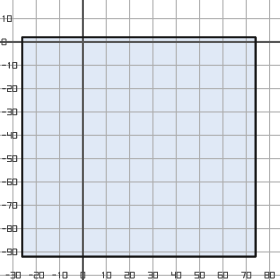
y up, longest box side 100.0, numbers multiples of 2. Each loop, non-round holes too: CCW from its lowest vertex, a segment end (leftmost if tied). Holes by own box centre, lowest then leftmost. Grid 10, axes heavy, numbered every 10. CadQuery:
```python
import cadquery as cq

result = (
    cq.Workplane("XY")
    .moveTo(-26.0, -92.0)
    .lineTo(74.0, -92.0)
    .lineTo(74.0, 2.0)
    .lineTo(-26.0, 2.0)
    .close()
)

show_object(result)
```